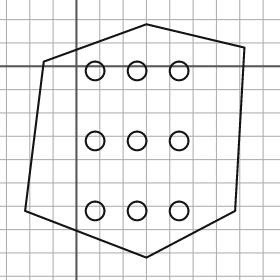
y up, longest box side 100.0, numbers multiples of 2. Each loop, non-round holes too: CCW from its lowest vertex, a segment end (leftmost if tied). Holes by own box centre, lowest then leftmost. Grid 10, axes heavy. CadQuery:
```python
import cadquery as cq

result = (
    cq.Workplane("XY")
    .moveTo(30.0, -82.0)
    .lineTo(68.0, -62.0)
    .lineTo(72.0, 8.0)
    .lineTo(30.0, 18.0)
    .lineTo(-14.0, 2.0)
    .lineTo(-22.0, -62.0)
    .close()
    .moveTo(8.0, -62.0)
    .circle(4.0)
    .moveTo(26.0, -62.0)
    .circle(4.0)
    .moveTo(44.0, -62.0)
    .circle(4.0)
    .moveTo(8.0, -32.0)
    .circle(4.0)
    .moveTo(26.0, -32.0)
    .circle(4.0)
    .moveTo(44.0, -32.0)
    .circle(4.0)
    .moveTo(8.0, -2.0)
    .circle(4.0)
    .moveTo(26.0, -2.0)
    .circle(4.0)
    .moveTo(44.0, -2.0)
    .circle(4.0)
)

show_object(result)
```